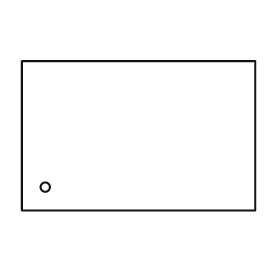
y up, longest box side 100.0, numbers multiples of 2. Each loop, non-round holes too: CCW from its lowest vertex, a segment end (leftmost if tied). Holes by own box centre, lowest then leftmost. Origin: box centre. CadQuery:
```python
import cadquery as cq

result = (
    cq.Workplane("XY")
    .moveTo(-50.0, -32.0)
    .lineTo(50.0, -32.0)
    .lineTo(50.0, 32.0)
    .lineTo(-50.0, 32.0)
    .close()
    .moveTo(-40.0, -22.0)
    .circle(2.0)
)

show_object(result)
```